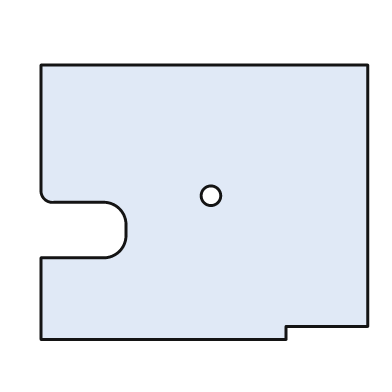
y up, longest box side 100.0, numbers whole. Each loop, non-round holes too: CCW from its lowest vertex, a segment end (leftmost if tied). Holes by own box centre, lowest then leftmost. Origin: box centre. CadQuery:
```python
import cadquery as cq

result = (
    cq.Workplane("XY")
    .moveTo(-50.0, -42.0)
    .lineTo(25.0, -42.0)
    .lineTo(25.0, -38.0)
    .lineTo(50.0, -38.0)
    .lineTo(50.0, 42.0)
    .lineTo(-50.0, 42.0)
    .lineTo(-50.0, 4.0)
    .threePointArc((-49.0, 1.0), (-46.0, 0.0))
    .lineTo(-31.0, 0.0)
    .threePointArc((-26.0, -2.0), (-24.0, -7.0))
    .lineTo(-24.0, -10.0)
    .threePointArc((-26.0, -15.0), (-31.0, -17.0))
    .lineTo(-50.0, -17.0)
    .close()
    .moveTo(2.0, 2.0)
    .circle(3.0)
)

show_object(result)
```